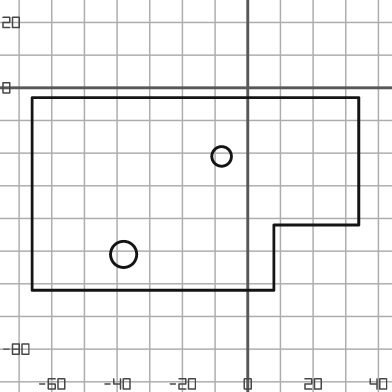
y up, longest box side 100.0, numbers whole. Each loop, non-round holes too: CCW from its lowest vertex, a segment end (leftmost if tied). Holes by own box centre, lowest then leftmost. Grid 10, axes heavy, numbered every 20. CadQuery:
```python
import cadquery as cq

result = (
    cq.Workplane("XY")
    .moveTo(-66.0, -62.0)
    .lineTo(8.0, -62.0)
    .lineTo(8.0, -42.0)
    .lineTo(34.0, -42.0)
    .lineTo(34.0, -3.0)
    .lineTo(-66.0, -3.0)
    .close()
    .moveTo(-38.0, -51.0)
    .circle(4.0)
    .moveTo(-8.0, -21.0)
    .circle(3.0)
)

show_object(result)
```